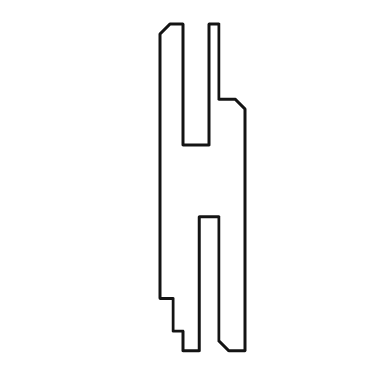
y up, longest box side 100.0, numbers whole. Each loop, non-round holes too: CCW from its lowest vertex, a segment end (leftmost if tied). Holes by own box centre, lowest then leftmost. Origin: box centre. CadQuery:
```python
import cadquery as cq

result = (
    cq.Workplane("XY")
    .moveTo(-6.0, -50.0)
    .lineTo(-1.0, -50.0)
    .lineTo(-1.0, -9.0)
    .lineTo(5.0, -9.0)
    .lineTo(5.0, -47.0)
    .lineTo(8.0, -50.0)
    .lineTo(13.0, -50.0)
    .lineTo(13.0, 24.0)
    .lineTo(10.0, 27.0)
    .lineTo(5.0, 27.0)
    .lineTo(5.0, 50.0)
    .lineTo(2.0, 50.0)
    .lineTo(2.0, 13.0)
    .lineTo(-6.0, 13.0)
    .lineTo(-6.0, 50.0)
    .lineTo(-10.0, 50.0)
    .lineTo(-13.0, 47.0)
    .lineTo(-13.0, -34.0)
    .lineTo(-9.0, -34.0)
    .lineTo(-9.0, -44.0)
    .lineTo(-6.0, -44.0)
    .close()
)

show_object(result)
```